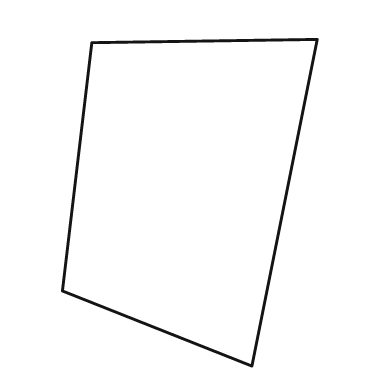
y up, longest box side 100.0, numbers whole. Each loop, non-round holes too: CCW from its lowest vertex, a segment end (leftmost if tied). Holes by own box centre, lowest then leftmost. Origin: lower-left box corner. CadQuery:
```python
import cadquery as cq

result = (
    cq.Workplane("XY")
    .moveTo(58.0, 0.0)
    .lineTo(78.0, 100.0)
    .lineTo(9.0, 99.0)
    .lineTo(0.0, 23.0)
    .close()
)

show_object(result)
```